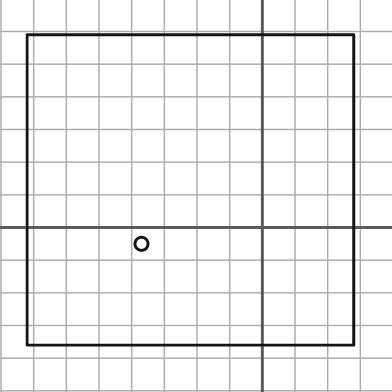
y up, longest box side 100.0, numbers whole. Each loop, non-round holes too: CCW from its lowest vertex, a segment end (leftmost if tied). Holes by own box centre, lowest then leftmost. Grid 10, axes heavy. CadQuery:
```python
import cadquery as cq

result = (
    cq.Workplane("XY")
    .moveTo(-72.0, -36.0)
    .lineTo(28.0, -36.0)
    .lineTo(28.0, 59.0)
    .lineTo(-72.0, 59.0)
    .close()
    .moveTo(-37.0, -5.0)
    .circle(2.0)
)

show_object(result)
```